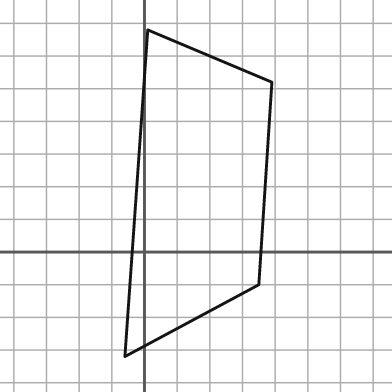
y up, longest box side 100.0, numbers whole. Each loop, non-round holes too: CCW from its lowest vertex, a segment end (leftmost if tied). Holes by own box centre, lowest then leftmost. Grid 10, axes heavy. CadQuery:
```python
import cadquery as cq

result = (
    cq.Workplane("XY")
    .moveTo(-6.0, -32.0)
    .lineTo(35.0, -10.0)
    .lineTo(39.0, 52.0)
    .lineTo(1.0, 68.0)
    .close()
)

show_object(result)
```